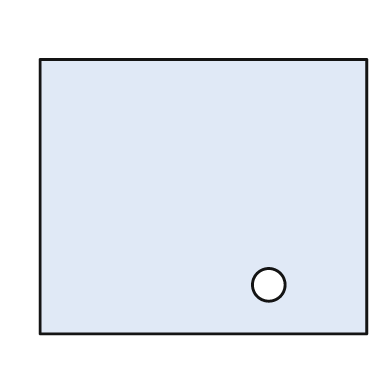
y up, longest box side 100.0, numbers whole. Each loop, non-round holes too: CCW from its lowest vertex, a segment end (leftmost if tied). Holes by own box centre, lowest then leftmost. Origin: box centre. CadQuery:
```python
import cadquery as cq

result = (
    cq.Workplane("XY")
    .moveTo(-50.0, -42.0)
    .lineTo(50.0, -42.0)
    .lineTo(50.0, 42.0)
    .lineTo(-50.0, 42.0)
    .close()
    .moveTo(20.0, -27.0)
    .circle(5.0)
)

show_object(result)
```